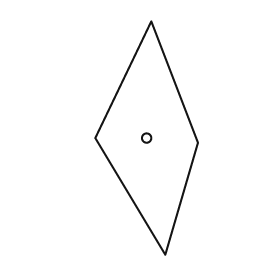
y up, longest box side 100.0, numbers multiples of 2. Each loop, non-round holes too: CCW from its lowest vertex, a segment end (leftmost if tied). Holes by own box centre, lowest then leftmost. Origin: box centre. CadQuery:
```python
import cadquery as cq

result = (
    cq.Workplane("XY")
    .moveTo(8.0, -50.0)
    .lineTo(22.0, -2.0)
    .lineTo(2.0, 50.0)
    .lineTo(-22.0, 0.0)
    .close()
    .moveTo(0.0, 0.0)
    .circle(2.0)
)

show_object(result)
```